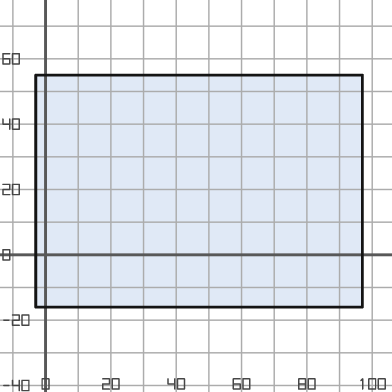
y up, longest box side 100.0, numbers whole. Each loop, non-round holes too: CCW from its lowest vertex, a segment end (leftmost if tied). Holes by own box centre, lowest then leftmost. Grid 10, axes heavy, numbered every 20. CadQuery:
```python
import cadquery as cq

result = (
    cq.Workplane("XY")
    .moveTo(-3.0, -16.0)
    .lineTo(97.0, -16.0)
    .lineTo(97.0, 55.0)
    .lineTo(-3.0, 55.0)
    .close()
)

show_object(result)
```